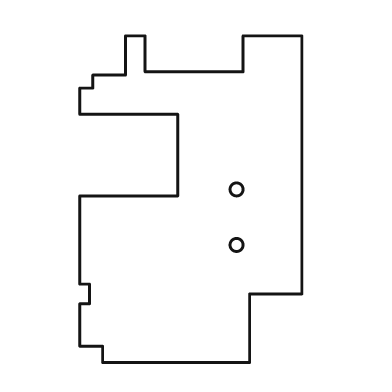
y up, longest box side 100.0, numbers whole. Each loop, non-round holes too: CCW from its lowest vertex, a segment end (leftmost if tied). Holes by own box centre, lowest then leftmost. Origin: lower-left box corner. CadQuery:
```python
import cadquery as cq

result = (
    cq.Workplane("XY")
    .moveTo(7.0, 0.0)
    .lineTo(52.0, 0.0)
    .lineTo(52.0, 21.0)
    .lineTo(68.0, 21.0)
    .lineTo(68.0, 100.0)
    .lineTo(50.0, 100.0)
    .lineTo(50.0, 89.0)
    .lineTo(20.0, 89.0)
    .lineTo(20.0, 100.0)
    .lineTo(14.0, 100.0)
    .lineTo(14.0, 88.0)
    .lineTo(4.0, 88.0)
    .lineTo(4.0, 84.0)
    .lineTo(0.0, 84.0)
    .lineTo(0.0, 76.0)
    .lineTo(30.0, 76.0)
    .lineTo(30.0, 51.0)
    .lineTo(0.0, 51.0)
    .lineTo(0.0, 24.0)
    .lineTo(3.0, 24.0)
    .lineTo(3.0, 18.0)
    .lineTo(0.0, 18.0)
    .lineTo(0.0, 5.0)
    .lineTo(7.0, 5.0)
    .close()
    .moveTo(48.0, 36.0)
    .circle(2.0)
    .moveTo(48.0, 53.0)
    .circle(2.0)
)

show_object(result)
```